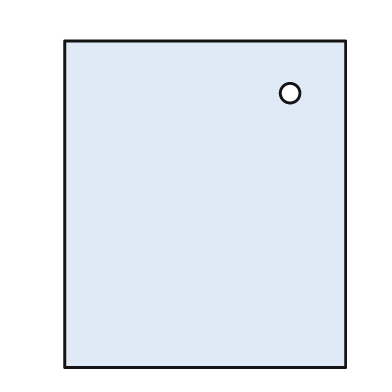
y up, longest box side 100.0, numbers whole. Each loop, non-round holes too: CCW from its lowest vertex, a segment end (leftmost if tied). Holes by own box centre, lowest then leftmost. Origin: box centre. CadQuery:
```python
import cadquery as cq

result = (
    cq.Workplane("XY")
    .moveTo(-43.0, -50.0)
    .lineTo(43.0, -50.0)
    .lineTo(43.0, 50.0)
    .lineTo(-43.0, 50.0)
    .close()
    .moveTo(26.0, 34.0)
    .circle(3.0)
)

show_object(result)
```